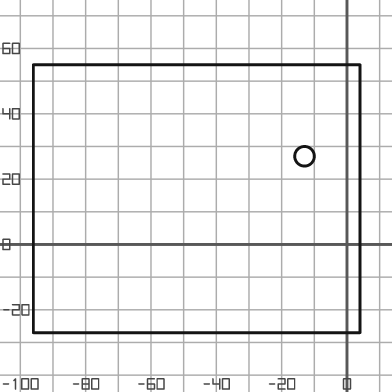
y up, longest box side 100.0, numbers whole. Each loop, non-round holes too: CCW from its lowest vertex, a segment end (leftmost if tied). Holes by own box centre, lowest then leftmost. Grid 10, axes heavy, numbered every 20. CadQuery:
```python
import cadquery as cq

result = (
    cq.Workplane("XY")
    .moveTo(-96.0, -27.0)
    .lineTo(4.0, -27.0)
    .lineTo(4.0, 55.0)
    .lineTo(-96.0, 55.0)
    .close()
    .moveTo(-13.0, 27.0)
    .circle(3.0)
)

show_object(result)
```